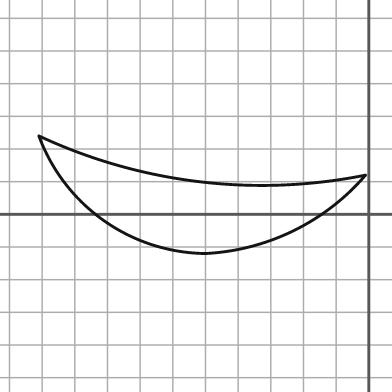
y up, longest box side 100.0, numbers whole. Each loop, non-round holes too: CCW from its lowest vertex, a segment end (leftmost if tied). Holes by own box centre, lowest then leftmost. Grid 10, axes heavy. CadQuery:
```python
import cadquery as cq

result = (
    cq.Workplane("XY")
    .moveTo(-50.0, -12.0)
    .threePointArc((-23.0, -5.0), (-1.0, 12.0))
    .threePointArc((-52.0, 10.0), (-101.0, 24.0))
    .threePointArc((-81.0, -2.0), (-50.0, -12.0))
    .close()
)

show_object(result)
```